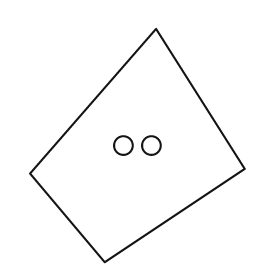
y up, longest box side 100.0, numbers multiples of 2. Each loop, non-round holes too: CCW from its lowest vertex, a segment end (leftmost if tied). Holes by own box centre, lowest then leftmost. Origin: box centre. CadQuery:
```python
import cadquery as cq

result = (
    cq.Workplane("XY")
    .moveTo(-14.0, -50.0)
    .lineTo(46.0, -10.0)
    .lineTo(8.0, 50.0)
    .lineTo(-46.0, -12.0)
    .close()
    .moveTo(-6.0, 0.0)
    .circle(4.0)
    .moveTo(6.0, 0.0)
    .circle(4.0)
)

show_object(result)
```